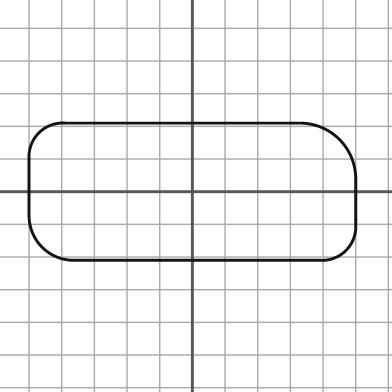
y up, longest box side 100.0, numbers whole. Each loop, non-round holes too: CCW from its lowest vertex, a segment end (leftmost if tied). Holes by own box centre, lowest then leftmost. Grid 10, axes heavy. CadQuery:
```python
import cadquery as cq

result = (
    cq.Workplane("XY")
    .moveTo(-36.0, -21.0)
    .lineTo(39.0, -21.0)
    .threePointArc((47.0, -18.0), (50.0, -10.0))
    .lineTo(50.0, 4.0)
    .threePointArc((45.0, 16.0), (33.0, 21.0))
    .lineTo(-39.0, 21.0)
    .threePointArc((-47.0, 18.0), (-50.0, 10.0))
    .lineTo(-50.0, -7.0)
    .threePointArc((-46.0, -17.0), (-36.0, -21.0))
    .close()
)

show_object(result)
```